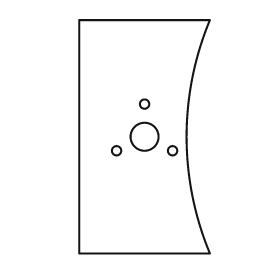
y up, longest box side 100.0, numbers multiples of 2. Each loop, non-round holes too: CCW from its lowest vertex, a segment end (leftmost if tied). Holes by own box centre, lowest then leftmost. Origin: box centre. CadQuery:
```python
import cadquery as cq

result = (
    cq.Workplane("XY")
    .moveTo(-28.0, -50.0)
    .lineTo(28.0, -50.0)
    .threePointArc((18.0, 0.0), (28.0, 50.0))
    .lineTo(-28.0, 50.0)
    .close()
    .moveTo(-12.0, -6.0)
    .circle(2.0)
    .moveTo(12.0, -6.0)
    .circle(2.0)
    .moveTo(0.0, 0.0)
    .circle(6.0)
    .moveTo(0.0, 14.0)
    .circle(2.0)
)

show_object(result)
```